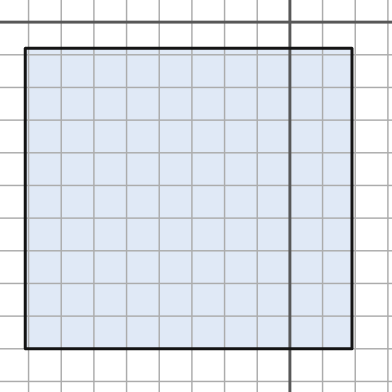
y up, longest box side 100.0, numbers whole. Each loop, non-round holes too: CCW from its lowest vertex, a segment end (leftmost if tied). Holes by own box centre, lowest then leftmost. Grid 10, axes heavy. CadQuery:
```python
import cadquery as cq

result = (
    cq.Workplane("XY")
    .moveTo(-81.0, -100.0)
    .lineTo(19.0, -100.0)
    .lineTo(19.0, -8.0)
    .lineTo(-81.0, -8.0)
    .close()
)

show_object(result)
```